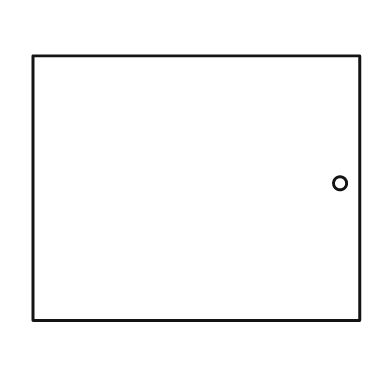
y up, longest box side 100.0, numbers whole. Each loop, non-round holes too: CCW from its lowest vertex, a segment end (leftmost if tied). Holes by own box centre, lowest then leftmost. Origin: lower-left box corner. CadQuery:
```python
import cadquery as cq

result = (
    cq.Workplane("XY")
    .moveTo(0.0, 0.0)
    .lineTo(100.0, 0.0)
    .lineTo(100.0, 81.0)
    .lineTo(0.0, 81.0)
    .close()
    .moveTo(94.0, 42.0)
    .circle(2.0)
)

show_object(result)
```